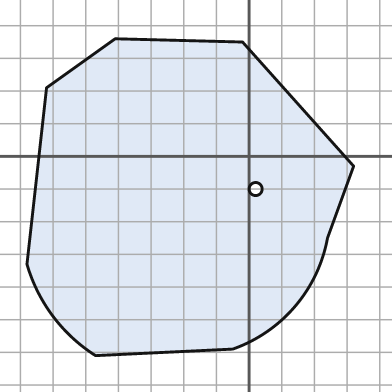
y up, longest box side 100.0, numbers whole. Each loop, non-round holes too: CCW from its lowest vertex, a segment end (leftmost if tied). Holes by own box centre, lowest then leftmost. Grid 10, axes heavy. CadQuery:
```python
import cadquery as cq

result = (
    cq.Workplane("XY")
    .moveTo(-47.0, -61.0)
    .lineTo(-5.0, -59.0)
    .threePointArc((14.0, -46.0), (24.0, -25.0))
    .lineTo(32.0, -3.0)
    .lineTo(-2.0, 35.0)
    .lineTo(-41.0, 36.0)
    .lineTo(-62.0, 21.0)
    .lineTo(-68.0, -33.0)
    .threePointArc((-60.0, -49.0), (-47.0, -61.0))
    .close()
    .moveTo(2.0, -10.0)
    .circle(2.0)
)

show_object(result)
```